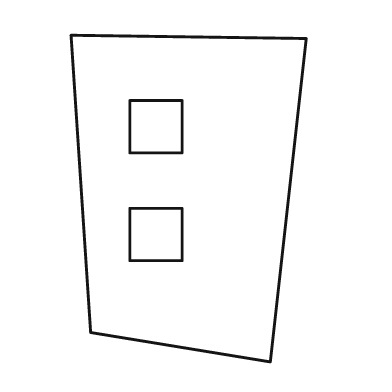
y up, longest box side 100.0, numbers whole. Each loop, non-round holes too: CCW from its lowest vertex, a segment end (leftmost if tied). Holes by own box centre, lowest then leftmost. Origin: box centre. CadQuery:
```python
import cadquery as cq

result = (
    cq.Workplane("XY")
    .moveTo(25.0, -50.0)
    .lineTo(36.0, 49.0)
    .lineTo(-36.0, 50.0)
    .lineTo(-30.0, -41.0)
    .close()
    .moveTo(-18.0, -19.0)
    .lineTo(-2.0, -19.0)
    .lineTo(-2.0, -3.0)
    .lineTo(-18.0, -3.0)
    .close()
    .moveTo(-18.0, 14.0)
    .lineTo(-2.0, 14.0)
    .lineTo(-2.0, 30.0)
    .lineTo(-18.0, 30.0)
    .close()
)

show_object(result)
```